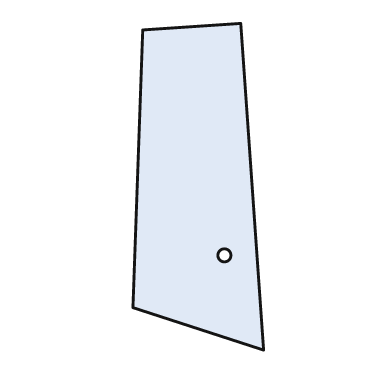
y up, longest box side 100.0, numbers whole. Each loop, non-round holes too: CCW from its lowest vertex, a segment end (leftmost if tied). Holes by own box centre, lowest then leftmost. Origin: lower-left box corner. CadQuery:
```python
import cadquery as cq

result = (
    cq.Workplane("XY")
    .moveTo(40.0, 0.0)
    .lineTo(33.0, 100.0)
    .lineTo(3.0, 98.0)
    .lineTo(0.0, 13.0)
    .close()
    .moveTo(28.0, 29.0)
    .circle(2.0)
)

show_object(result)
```